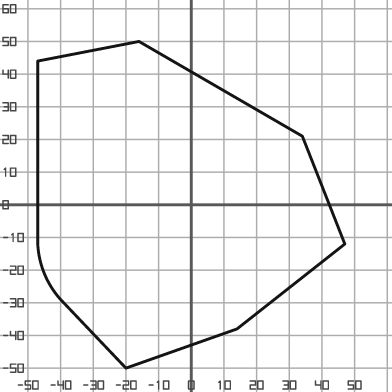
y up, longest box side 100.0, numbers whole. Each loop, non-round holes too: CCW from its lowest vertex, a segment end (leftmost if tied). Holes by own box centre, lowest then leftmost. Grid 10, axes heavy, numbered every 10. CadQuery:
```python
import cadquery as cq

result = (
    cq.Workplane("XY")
    .moveTo(-20.0, -50.0)
    .lineTo(14.0, -38.0)
    .lineTo(47.0, -12.0)
    .lineTo(34.0, 21.0)
    .lineTo(-16.0, 50.0)
    .lineTo(-47.0, 44.0)
    .lineTo(-47.0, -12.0)
    .threePointArc((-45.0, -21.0), (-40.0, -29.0))
    .close()
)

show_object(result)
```